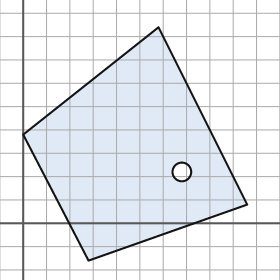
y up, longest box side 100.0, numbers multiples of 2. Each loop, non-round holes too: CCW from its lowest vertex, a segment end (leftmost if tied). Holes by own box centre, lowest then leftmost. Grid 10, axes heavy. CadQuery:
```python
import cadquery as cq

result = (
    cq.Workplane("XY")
    .moveTo(28.0, -16.0)
    .lineTo(96.0, 8.0)
    .lineTo(58.0, 84.0)
    .lineTo(0.0, 38.0)
    .close()
    .moveTo(68.0, 22.0)
    .circle(4.0)
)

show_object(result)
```